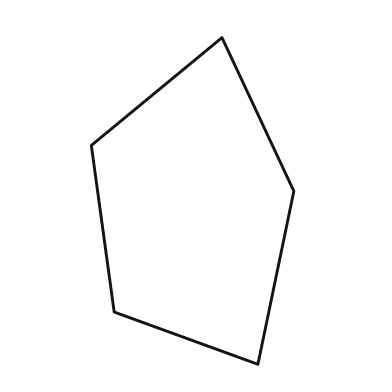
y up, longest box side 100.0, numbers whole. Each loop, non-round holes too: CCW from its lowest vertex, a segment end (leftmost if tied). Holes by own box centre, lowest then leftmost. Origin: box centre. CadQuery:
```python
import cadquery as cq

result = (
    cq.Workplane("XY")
    .moveTo(20.0, -50.0)
    .lineTo(31.0, 3.0)
    .lineTo(9.0, 50.0)
    .lineTo(-31.0, 17.0)
    .lineTo(-24.0, -34.0)
    .close()
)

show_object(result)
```